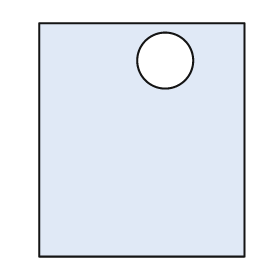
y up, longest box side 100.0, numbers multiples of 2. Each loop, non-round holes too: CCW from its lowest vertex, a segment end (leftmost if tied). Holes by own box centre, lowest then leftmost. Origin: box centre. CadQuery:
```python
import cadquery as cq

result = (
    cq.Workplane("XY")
    .moveTo(-44.0, -50.0)
    .lineTo(44.0, -50.0)
    .lineTo(44.0, 50.0)
    .lineTo(-44.0, 50.0)
    .close()
    .moveTo(10.0, 34.0)
    .circle(12.0)
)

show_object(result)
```